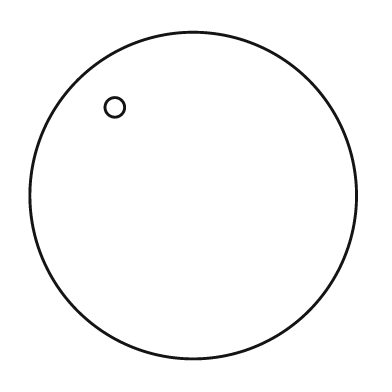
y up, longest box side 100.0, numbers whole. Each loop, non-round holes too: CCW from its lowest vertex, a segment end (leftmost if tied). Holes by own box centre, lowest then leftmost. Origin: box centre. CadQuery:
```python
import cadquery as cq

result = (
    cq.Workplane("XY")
    .moveTo(0.0, 0.0)
    .circle(50.0)
    .moveTo(-24.0, 27.0)
    .circle(3.0)
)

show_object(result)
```